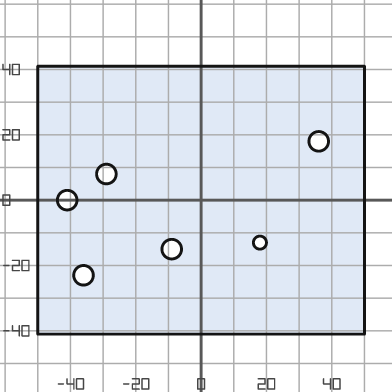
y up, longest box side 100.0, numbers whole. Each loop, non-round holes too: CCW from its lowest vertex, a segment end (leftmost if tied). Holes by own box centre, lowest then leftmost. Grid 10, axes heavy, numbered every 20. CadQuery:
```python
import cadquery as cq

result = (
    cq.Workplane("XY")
    .moveTo(-50.0, -41.0)
    .lineTo(50.0, -41.0)
    .lineTo(50.0, 41.0)
    .lineTo(-50.0, 41.0)
    .close()
    .moveTo(-36.0, -23.0)
    .circle(3.0)
    .moveTo(-9.0, -15.0)
    .circle(3.0)
    .moveTo(18.0, -13.0)
    .circle(2.0)
    .moveTo(-41.0, 0.0)
    .circle(3.0)
    .moveTo(-29.0, 8.0)
    .circle(3.0)
    .moveTo(36.0, 18.0)
    .circle(3.0)
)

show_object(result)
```